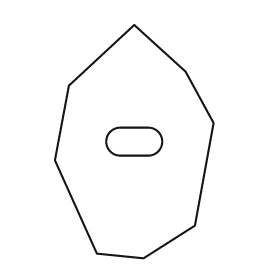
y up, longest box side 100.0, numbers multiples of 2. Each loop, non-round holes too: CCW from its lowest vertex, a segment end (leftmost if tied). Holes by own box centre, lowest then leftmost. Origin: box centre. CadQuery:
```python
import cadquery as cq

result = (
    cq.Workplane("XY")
    .moveTo(4.0, -50.0)
    .lineTo(26.0, -36.0)
    .lineTo(34.0, 8.0)
    .lineTo(22.0, 30.0)
    .lineTo(0.0, 50.0)
    .lineTo(-28.0, 24.0)
    .lineTo(-34.0, -8.0)
    .lineTo(-16.0, -48.0)
    .close()
    .moveTo(-6.0, -6.0)
    .lineTo(6.0, -6.0)
    .threePointArc((12.0, 0.0), (6.0, 6.0))
    .lineTo(-6.0, 6.0)
    .threePointArc((-12.0, 0.0), (-6.0, -6.0))
    .close()
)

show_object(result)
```